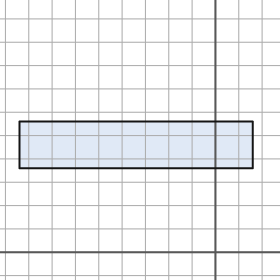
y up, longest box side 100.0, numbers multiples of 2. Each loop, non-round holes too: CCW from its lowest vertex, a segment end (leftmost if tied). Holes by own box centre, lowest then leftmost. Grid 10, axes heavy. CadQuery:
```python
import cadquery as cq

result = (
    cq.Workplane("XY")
    .moveTo(-84.0, 36.0)
    .lineTo(16.0, 36.0)
    .lineTo(16.0, 56.0)
    .lineTo(-84.0, 56.0)
    .close()
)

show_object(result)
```